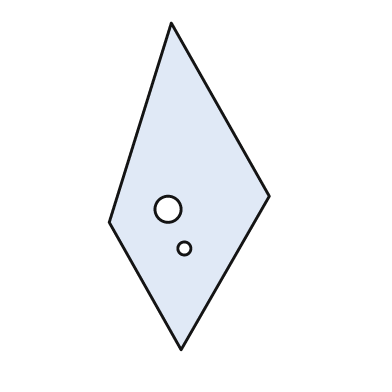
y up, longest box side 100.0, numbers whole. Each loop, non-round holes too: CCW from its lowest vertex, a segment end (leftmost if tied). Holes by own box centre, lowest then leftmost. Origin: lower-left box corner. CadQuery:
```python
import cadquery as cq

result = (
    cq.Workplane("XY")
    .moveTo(22.0, 0.0)
    .lineTo(49.0, 47.0)
    .lineTo(19.0, 100.0)
    .lineTo(0.0, 39.0)
    .close()
    .moveTo(23.0, 31.0)
    .circle(2.0)
    .moveTo(18.0, 43.0)
    .circle(4.0)
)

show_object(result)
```